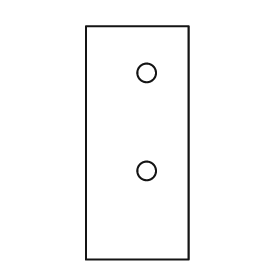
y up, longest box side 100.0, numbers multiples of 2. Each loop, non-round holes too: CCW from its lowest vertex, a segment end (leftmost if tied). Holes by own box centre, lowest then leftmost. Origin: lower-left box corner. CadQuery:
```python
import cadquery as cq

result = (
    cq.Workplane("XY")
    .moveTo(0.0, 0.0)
    .lineTo(44.0, 0.0)
    .lineTo(44.0, 100.0)
    .lineTo(0.0, 100.0)
    .close()
    .moveTo(26.0, 38.0)
    .circle(4.0)
    .moveTo(26.0, 80.0)
    .circle(4.0)
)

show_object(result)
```